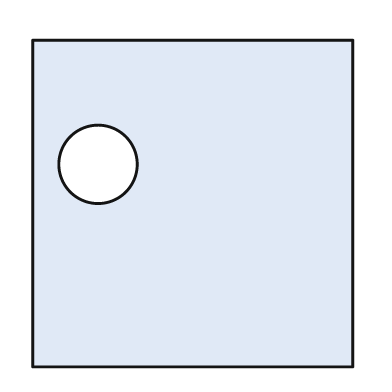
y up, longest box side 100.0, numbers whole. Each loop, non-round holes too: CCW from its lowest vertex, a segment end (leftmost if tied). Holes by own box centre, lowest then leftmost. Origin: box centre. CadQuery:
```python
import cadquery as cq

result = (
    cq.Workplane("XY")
    .moveTo(-49.0, -50.0)
    .lineTo(49.0, -50.0)
    .lineTo(49.0, 50.0)
    .lineTo(-49.0, 50.0)
    .close()
    .moveTo(-29.0, 12.0)
    .circle(12.0)
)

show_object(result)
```